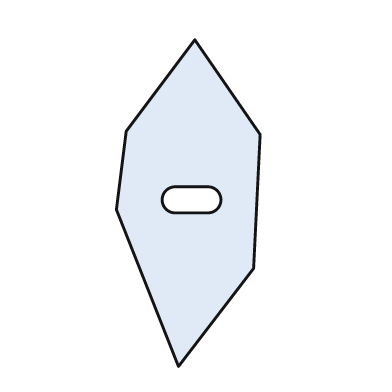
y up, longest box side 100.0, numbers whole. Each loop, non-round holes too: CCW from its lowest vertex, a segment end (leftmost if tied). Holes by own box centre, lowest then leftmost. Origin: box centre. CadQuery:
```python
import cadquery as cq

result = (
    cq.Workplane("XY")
    .moveTo(-3.0, -50.0)
    .lineTo(20.0, -20.0)
    .lineTo(22.0, 21.0)
    .lineTo(2.0, 50.0)
    .lineTo(-19.0, 22.0)
    .lineTo(-22.0, -2.0)
    .close()
    .moveTo(-4.0, -3.0)
    .lineTo(6.0, -3.0)
    .threePointArc((10.0, 1.0), (6.0, 5.0))
    .lineTo(-4.0, 5.0)
    .threePointArc((-8.0, 1.0), (-4.0, -3.0))
    .close()
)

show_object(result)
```